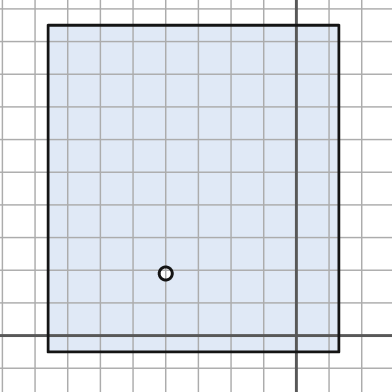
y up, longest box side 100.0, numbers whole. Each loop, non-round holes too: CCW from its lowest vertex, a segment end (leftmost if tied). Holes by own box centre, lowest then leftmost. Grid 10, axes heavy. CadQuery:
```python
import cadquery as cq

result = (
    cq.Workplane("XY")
    .moveTo(-76.0, -5.0)
    .lineTo(13.0, -5.0)
    .lineTo(13.0, 95.0)
    .lineTo(-76.0, 95.0)
    .close()
    .moveTo(-40.0, 19.0)
    .circle(2.0)
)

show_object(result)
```